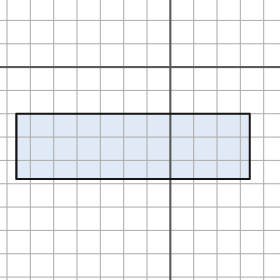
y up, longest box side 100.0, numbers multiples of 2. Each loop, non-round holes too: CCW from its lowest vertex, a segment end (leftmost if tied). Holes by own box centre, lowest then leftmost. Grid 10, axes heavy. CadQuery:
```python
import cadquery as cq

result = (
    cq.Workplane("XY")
    .moveTo(-66.0, -48.0)
    .lineTo(34.0, -48.0)
    .lineTo(34.0, -20.0)
    .lineTo(-66.0, -20.0)
    .close()
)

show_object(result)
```